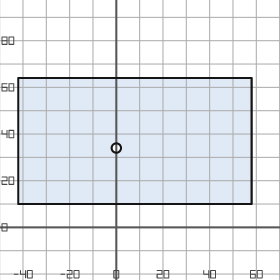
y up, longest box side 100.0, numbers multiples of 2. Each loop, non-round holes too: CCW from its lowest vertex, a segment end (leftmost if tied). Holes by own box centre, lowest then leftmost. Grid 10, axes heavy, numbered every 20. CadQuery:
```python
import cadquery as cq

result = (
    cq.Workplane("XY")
    .moveTo(-42.0, 10.0)
    .lineTo(58.0, 10.0)
    .lineTo(58.0, 64.0)
    .lineTo(-42.0, 64.0)
    .close()
    .moveTo(0.0, 34.0)
    .circle(2.0)
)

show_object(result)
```